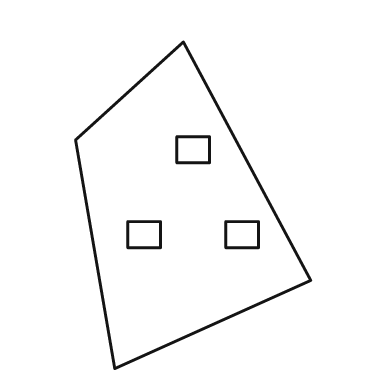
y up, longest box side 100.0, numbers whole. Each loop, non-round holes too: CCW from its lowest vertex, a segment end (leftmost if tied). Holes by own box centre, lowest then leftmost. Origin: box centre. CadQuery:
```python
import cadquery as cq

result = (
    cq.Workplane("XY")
    .moveTo(-24.0, -50.0)
    .lineTo(36.0, -23.0)
    .lineTo(-3.0, 50.0)
    .lineTo(-36.0, 20.0)
    .close()
    .moveTo(-20.0, -13.0)
    .lineTo(-10.0, -13.0)
    .lineTo(-10.0, -5.0)
    .lineTo(-20.0, -5.0)
    .close()
    .moveTo(10.0, -13.0)
    .lineTo(20.0, -13.0)
    .lineTo(20.0, -5.0)
    .lineTo(10.0, -5.0)
    .close()
    .moveTo(-5.0, 13.0)
    .lineTo(5.0, 13.0)
    .lineTo(5.0, 21.0)
    .lineTo(-5.0, 21.0)
    .close()
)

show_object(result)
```